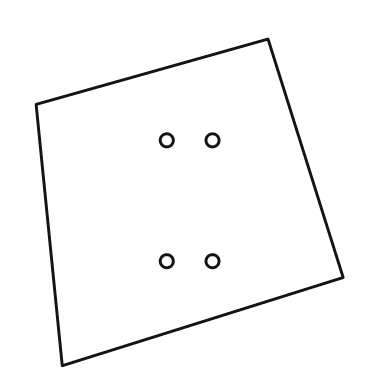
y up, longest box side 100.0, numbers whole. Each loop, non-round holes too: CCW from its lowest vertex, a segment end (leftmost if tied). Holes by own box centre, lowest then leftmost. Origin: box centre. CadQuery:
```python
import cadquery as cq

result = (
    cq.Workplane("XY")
    .moveTo(-39.0, -50.0)
    .lineTo(47.0, -23.0)
    .lineTo(24.0, 50.0)
    .lineTo(-47.0, 30.0)
    .close()
    .moveTo(-7.0, -18.0)
    .circle(2.0)
    .moveTo(7.0, -18.0)
    .circle(2.0)
    .moveTo(-7.0, 19.0)
    .circle(2.0)
    .moveTo(7.0, 19.0)
    .circle(2.0)
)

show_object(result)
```